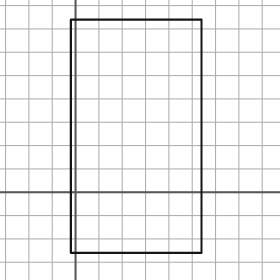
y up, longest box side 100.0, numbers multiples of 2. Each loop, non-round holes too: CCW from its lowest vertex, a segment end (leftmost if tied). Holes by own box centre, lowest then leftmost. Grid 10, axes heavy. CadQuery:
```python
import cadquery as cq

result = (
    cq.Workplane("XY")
    .moveTo(-2.0, -26.0)
    .lineTo(54.0, -26.0)
    .lineTo(54.0, 74.0)
    .lineTo(-2.0, 74.0)
    .close()
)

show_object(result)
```